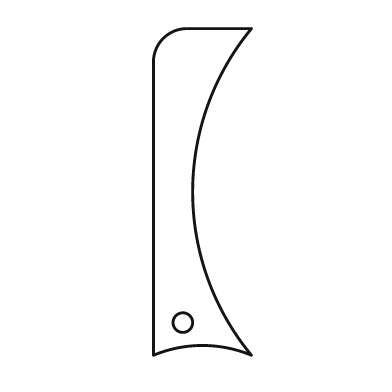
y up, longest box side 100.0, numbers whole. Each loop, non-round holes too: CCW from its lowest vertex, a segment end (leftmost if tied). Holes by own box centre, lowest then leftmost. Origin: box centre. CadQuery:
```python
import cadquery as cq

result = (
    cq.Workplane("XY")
    .moveTo(-15.0, -50.0)
    .threePointArc((0.0, -47.0), (15.0, -50.0))
    .threePointArc((-3.0, 0.0), (15.0, 50.0))
    .lineTo(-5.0, 50.0)
    .threePointArc((-12.0, 47.0), (-15.0, 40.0))
    .close()
    .moveTo(-6.0, -40.0)
    .circle(3.0)
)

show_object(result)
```